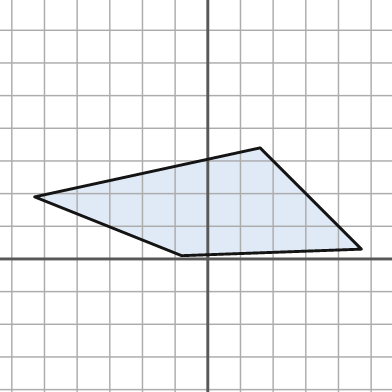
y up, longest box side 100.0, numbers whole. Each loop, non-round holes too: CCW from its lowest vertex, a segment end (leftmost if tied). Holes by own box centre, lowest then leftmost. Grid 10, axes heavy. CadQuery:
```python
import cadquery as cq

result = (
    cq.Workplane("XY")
    .moveTo(-8.0, 1.0)
    .lineTo(47.0, 3.0)
    .lineTo(16.0, 34.0)
    .lineTo(-53.0, 19.0)
    .close()
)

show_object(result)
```